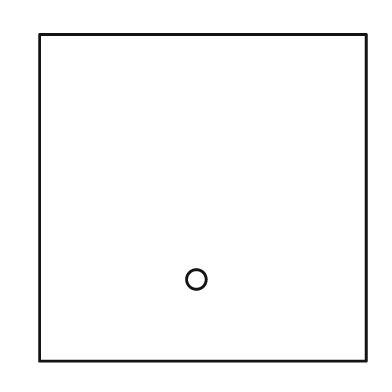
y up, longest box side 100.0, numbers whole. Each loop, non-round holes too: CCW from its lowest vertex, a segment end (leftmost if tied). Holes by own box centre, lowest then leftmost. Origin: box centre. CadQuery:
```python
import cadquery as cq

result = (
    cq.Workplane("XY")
    .moveTo(-50.0, -50.0)
    .lineTo(50.0, -50.0)
    .lineTo(50.0, 50.0)
    .lineTo(-50.0, 50.0)
    .close()
    .moveTo(-2.0, -25.0)
    .circle(3.0)
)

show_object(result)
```